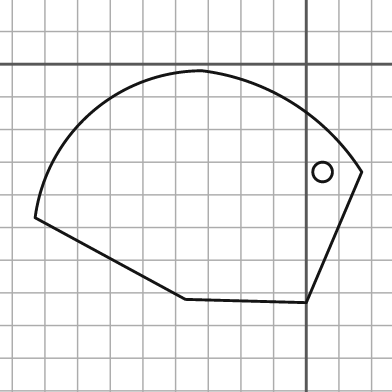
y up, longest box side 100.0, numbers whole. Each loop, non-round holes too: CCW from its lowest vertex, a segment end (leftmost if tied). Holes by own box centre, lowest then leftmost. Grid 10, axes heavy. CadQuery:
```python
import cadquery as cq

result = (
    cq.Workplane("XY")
    .moveTo(0.0, -73.0)
    .lineTo(17.0, -33.0)
    .threePointArc((-4.0, -12.0), (-32.0, -2.0))
    .threePointArc((-66.0, -15.0), (-83.0, -47.0))
    .lineTo(-37.0, -72.0)
    .close()
    .moveTo(5.0, -33.0)
    .circle(3.0)
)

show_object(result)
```